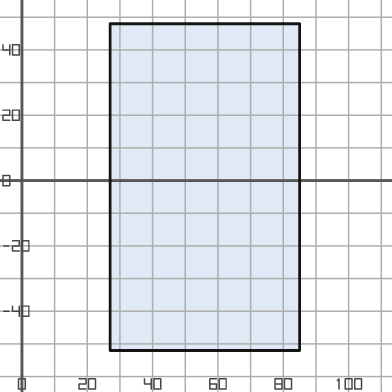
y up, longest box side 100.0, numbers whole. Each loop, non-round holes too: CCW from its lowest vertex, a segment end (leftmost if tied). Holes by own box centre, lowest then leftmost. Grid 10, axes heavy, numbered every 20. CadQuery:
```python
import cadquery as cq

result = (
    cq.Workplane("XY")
    .moveTo(27.0, -52.0)
    .lineTo(85.0, -52.0)
    .lineTo(85.0, 48.0)
    .lineTo(27.0, 48.0)
    .close()
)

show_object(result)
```